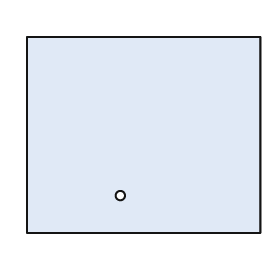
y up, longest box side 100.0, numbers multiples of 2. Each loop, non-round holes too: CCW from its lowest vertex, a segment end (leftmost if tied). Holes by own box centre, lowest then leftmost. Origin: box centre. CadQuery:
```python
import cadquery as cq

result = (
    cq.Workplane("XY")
    .moveTo(-50.0, -42.0)
    .lineTo(50.0, -42.0)
    .lineTo(50.0, 42.0)
    .lineTo(-50.0, 42.0)
    .close()
    .moveTo(-10.0, -26.0)
    .circle(2.0)
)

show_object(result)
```